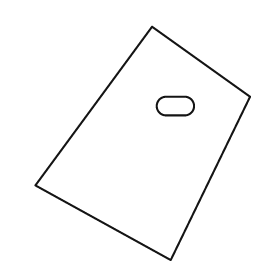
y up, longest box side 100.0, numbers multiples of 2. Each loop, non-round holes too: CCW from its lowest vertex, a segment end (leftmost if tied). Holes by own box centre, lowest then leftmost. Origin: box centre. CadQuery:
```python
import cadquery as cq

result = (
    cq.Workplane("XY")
    .moveTo(12.0, -50.0)
    .lineTo(46.0, 20.0)
    .lineTo(4.0, 50.0)
    .lineTo(-46.0, -18.0)
    .close()
    .moveTo(10.0, 12.0)
    .lineTo(18.0, 12.0)
    .threePointArc((22.0, 16.0), (18.0, 20.0))
    .lineTo(10.0, 20.0)
    .threePointArc((6.0, 16.0), (10.0, 12.0))
    .close()
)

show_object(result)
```